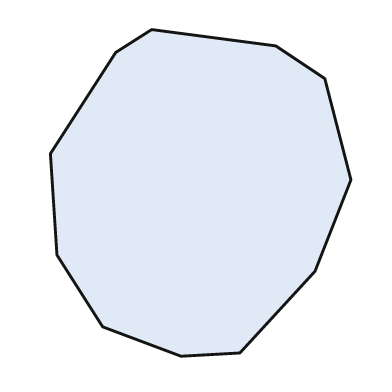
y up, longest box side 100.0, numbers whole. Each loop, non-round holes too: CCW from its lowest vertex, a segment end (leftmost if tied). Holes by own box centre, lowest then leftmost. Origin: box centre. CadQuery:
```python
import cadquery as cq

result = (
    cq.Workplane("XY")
    .moveTo(-6.0, -50.0)
    .lineTo(12.0, -49.0)
    .lineTo(35.0, -24.0)
    .lineTo(46.0, 4.0)
    .lineTo(38.0, 35.0)
    .lineTo(23.0, 45.0)
    .lineTo(-15.0, 50.0)
    .lineTo(-26.0, 43.0)
    .lineTo(-46.0, 12.0)
    .lineTo(-44.0, -19.0)
    .lineTo(-30.0, -41.0)
    .close()
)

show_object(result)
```